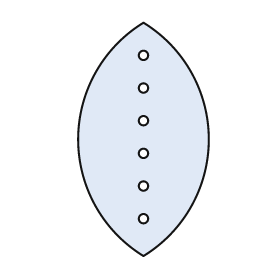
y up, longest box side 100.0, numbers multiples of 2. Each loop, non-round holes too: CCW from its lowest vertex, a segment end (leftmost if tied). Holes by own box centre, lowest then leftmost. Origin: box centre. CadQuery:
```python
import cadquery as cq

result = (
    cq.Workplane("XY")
    .moveTo(0.0, -50.0)
    .threePointArc((28.0, 0.0), (0.0, 50.0))
    .threePointArc((-28.0, 0.0), (0.0, -50.0))
    .close()
    .moveTo(0.0, -34.0)
    .circle(2.0)
    .moveTo(0.0, -20.0)
    .circle(2.0)
    .moveTo(0.0, -6.0)
    .circle(2.0)
    .moveTo(0.0, 8.0)
    .circle(2.0)
    .moveTo(0.0, 22.0)
    .circle(2.0)
    .moveTo(0.0, 36.0)
    .circle(2.0)
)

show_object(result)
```